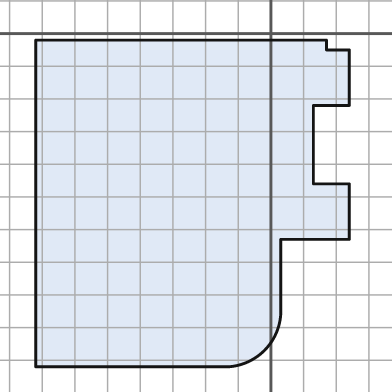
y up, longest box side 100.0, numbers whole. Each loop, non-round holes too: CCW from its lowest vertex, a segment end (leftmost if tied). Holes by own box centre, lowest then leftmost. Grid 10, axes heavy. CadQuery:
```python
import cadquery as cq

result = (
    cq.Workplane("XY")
    .moveTo(-72.0, -102.0)
    .lineTo(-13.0, -102.0)
    .threePointArc((-2.0, -97.0), (3.0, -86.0))
    .lineTo(3.0, -63.0)
    .lineTo(24.0, -63.0)
    .lineTo(24.0, -46.0)
    .lineTo(13.0, -46.0)
    .lineTo(13.0, -22.0)
    .lineTo(24.0, -22.0)
    .lineTo(24.0, -5.0)
    .lineTo(17.0, -5.0)
    .lineTo(17.0, -2.0)
    .lineTo(-72.0, -2.0)
    .close()
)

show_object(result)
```